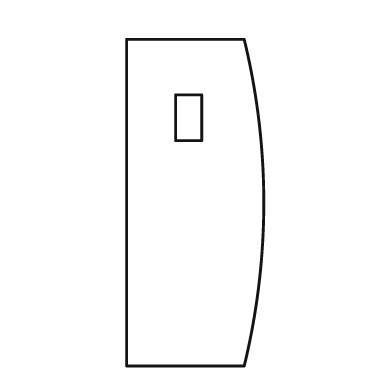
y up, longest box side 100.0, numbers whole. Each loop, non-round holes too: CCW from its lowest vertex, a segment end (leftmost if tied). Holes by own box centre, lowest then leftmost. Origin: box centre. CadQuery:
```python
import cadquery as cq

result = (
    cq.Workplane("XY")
    .moveTo(-21.0, -50.0)
    .lineTo(15.0, -50.0)
    .threePointArc((21.0, 0.0), (15.0, 50.0))
    .lineTo(-21.0, 50.0)
    .close()
    .moveTo(-6.0, 19.0)
    .lineTo(2.0, 19.0)
    .lineTo(2.0, 33.0)
    .lineTo(-6.0, 33.0)
    .close()
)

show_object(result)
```